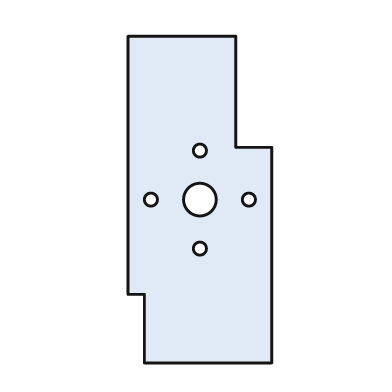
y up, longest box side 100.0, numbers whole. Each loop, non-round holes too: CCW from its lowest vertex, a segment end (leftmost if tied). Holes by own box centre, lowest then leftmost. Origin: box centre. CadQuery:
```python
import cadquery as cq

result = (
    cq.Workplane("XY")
    .moveTo(-17.0, -50.0)
    .lineTo(22.0, -50.0)
    .lineTo(22.0, 16.0)
    .lineTo(11.0, 16.0)
    .lineTo(11.0, 50.0)
    .lineTo(-22.0, 50.0)
    .lineTo(-22.0, -29.0)
    .lineTo(-17.0, -29.0)
    .close()
    .moveTo(0.0, -15.0)
    .circle(2.0)
    .moveTo(-15.0, 0.0)
    .circle(2.0)
    .moveTo(0.0, 0.0)
    .circle(5.0)
    .moveTo(15.0, 0.0)
    .circle(2.0)
    .moveTo(0.0, 15.0)
    .circle(2.0)
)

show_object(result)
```